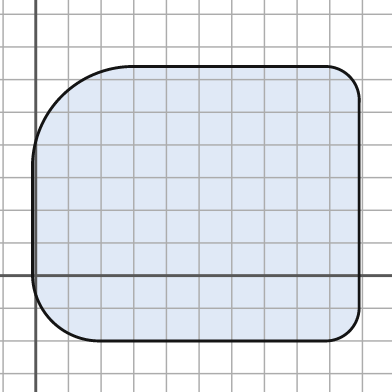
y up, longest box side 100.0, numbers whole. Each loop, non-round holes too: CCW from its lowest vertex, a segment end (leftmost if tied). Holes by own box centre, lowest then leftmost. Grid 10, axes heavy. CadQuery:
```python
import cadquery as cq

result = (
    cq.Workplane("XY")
    .moveTo(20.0, -20.0)
    .lineTo(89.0, -20.0)
    .threePointArc((96.0, -17.0), (99.0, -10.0))
    .lineTo(99.0, 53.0)
    .threePointArc((96.0, 61.0), (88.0, 64.0))
    .lineTo(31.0, 64.0)
    .threePointArc((8.0, 55.0), (-1.0, 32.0))
    .lineTo(-1.0, 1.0)
    .threePointArc((5.0, -14.0), (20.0, -20.0))
    .close()
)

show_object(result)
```